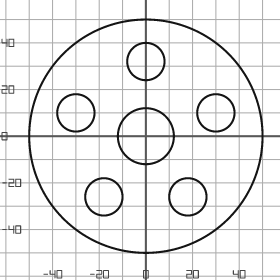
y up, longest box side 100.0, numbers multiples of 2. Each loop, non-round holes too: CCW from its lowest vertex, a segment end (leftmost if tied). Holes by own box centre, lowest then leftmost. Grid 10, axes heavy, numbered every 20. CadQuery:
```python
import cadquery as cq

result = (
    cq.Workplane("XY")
    .moveTo(0.0, 0.0)
    .circle(50.0)
    .moveTo(-18.0, -26.0)
    .circle(8.0)
    .moveTo(18.0, -26.0)
    .circle(8.0)
    .moveTo(0.0, 0.0)
    .circle(12.0)
    .moveTo(-30.0, 10.0)
    .circle(8.0)
    .moveTo(30.0, 10.0)
    .circle(8.0)
    .moveTo(0.0, 32.0)
    .circle(8.0)
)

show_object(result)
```